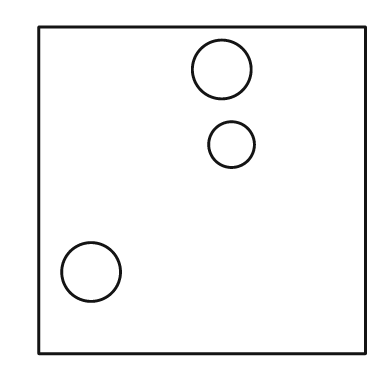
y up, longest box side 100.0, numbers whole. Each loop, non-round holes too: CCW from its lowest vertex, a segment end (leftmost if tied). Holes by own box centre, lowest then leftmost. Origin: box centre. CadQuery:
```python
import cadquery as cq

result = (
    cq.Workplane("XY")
    .moveTo(-50.0, -50.0)
    .lineTo(50.0, -50.0)
    .lineTo(50.0, 50.0)
    .lineTo(-50.0, 50.0)
    .close()
    .moveTo(-34.0, -25.0)
    .circle(9.0)
    .moveTo(9.0, 14.0)
    .circle(7.0)
    .moveTo(6.0, 37.0)
    .circle(9.0)
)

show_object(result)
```